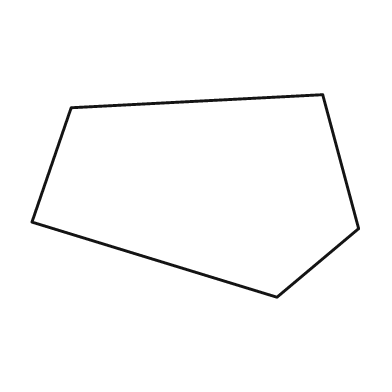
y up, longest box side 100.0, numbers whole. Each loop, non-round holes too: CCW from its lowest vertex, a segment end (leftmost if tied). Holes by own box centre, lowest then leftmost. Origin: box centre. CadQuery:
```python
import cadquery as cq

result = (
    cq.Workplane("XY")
    .moveTo(25.0, -31.0)
    .lineTo(50.0, -10.0)
    .lineTo(39.0, 31.0)
    .lineTo(-38.0, 27.0)
    .lineTo(-50.0, -8.0)
    .close()
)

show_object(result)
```